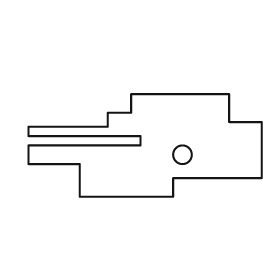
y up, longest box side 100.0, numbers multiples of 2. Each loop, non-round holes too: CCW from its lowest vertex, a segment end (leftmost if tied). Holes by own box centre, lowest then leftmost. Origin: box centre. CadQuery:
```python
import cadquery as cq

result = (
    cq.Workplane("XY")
    .moveTo(-28.0, -22.0)
    .lineTo(12.0, -22.0)
    .lineTo(12.0, -14.0)
    .lineTo(50.0, -14.0)
    .lineTo(50.0, 10.0)
    .lineTo(36.0, 10.0)
    .lineTo(36.0, 22.0)
    .lineTo(-6.0, 22.0)
    .lineTo(-6.0, 14.0)
    .lineTo(-16.0, 14.0)
    .lineTo(-16.0, 8.0)
    .lineTo(-50.0, 8.0)
    .lineTo(-50.0, 4.0)
    .lineTo(-2.0, 4.0)
    .lineTo(-2.0, 0.0)
    .lineTo(-50.0, 0.0)
    .lineTo(-50.0, -8.0)
    .lineTo(-28.0, -8.0)
    .close()
    .moveTo(16.0, -4.0)
    .circle(4.0)
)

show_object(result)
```